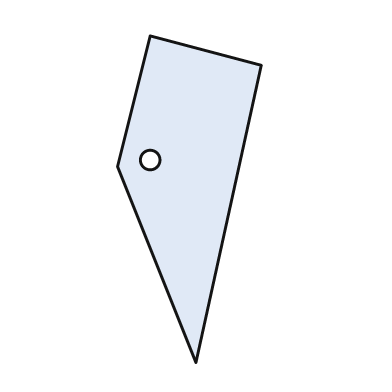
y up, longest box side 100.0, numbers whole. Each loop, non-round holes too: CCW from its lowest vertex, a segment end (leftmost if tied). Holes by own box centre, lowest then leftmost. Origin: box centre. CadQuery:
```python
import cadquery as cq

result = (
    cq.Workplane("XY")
    .moveTo(2.0, -50.0)
    .lineTo(22.0, 41.0)
    .lineTo(-12.0, 50.0)
    .lineTo(-22.0, 10.0)
    .close()
    .moveTo(-12.0, 12.0)
    .circle(3.0)
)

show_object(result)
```